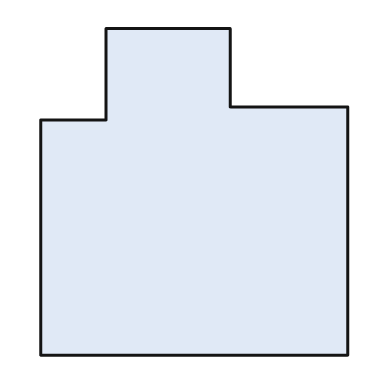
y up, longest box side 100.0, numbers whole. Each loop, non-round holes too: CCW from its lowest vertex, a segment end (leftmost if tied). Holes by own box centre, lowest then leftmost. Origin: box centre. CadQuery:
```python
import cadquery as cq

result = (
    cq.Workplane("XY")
    .moveTo(-47.0, -50.0)
    .lineTo(47.0, -50.0)
    .lineTo(47.0, 26.0)
    .lineTo(11.0, 26.0)
    .lineTo(11.0, 50.0)
    .lineTo(-27.0, 50.0)
    .lineTo(-27.0, 22.0)
    .lineTo(-47.0, 22.0)
    .close()
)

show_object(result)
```